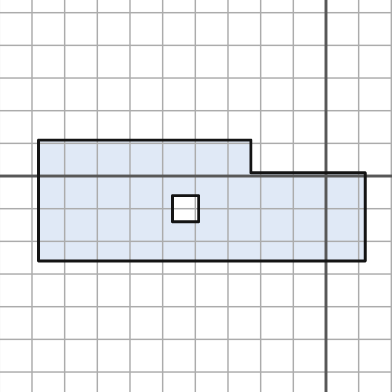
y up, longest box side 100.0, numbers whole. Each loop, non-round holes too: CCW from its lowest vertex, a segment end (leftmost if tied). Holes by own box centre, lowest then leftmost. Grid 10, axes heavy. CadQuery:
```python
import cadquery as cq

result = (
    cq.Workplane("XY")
    .moveTo(-88.0, -26.0)
    .lineTo(12.0, -26.0)
    .lineTo(12.0, 1.0)
    .lineTo(-23.0, 1.0)
    .lineTo(-23.0, 11.0)
    .lineTo(-88.0, 11.0)
    .close()
    .moveTo(-47.0, -14.0)
    .lineTo(-39.0, -14.0)
    .lineTo(-39.0, -6.0)
    .lineTo(-47.0, -6.0)
    .close()
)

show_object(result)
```